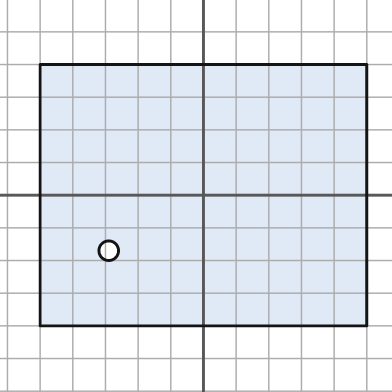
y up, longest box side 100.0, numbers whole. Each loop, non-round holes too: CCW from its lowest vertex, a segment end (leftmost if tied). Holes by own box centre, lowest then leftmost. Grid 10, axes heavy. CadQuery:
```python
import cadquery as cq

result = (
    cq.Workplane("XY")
    .moveTo(-50.0, -40.0)
    .lineTo(50.0, -40.0)
    .lineTo(50.0, 40.0)
    .lineTo(-50.0, 40.0)
    .close()
    .moveTo(-29.0, -17.0)
    .circle(3.0)
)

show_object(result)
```